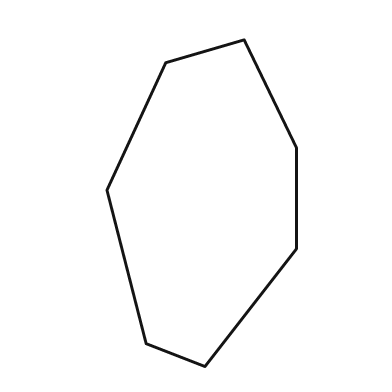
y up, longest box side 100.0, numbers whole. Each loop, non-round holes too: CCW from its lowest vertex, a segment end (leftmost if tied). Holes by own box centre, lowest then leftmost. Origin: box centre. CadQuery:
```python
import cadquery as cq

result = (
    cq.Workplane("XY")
    .moveTo(1.0, -50.0)
    .lineTo(29.0, -14.0)
    .lineTo(29.0, 17.0)
    .lineTo(13.0, 50.0)
    .lineTo(-11.0, 43.0)
    .lineTo(-29.0, 4.0)
    .lineTo(-17.0, -43.0)
    .close()
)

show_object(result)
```